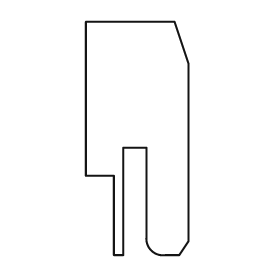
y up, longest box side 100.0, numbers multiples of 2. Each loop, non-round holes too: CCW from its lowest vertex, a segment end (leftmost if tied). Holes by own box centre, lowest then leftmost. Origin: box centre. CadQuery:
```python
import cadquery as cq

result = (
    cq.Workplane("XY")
    .moveTo(-10.0, -50.0)
    .lineTo(-6.0, -50.0)
    .lineTo(-6.0, -4.0)
    .lineTo(4.0, -4.0)
    .lineTo(4.0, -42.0)
    .threePointArc((6.0, -48.0), (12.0, -50.0))
    .lineTo(18.0, -50.0)
    .lineTo(22.0, -44.0)
    .lineTo(22.0, 32.0)
    .lineTo(16.0, 50.0)
    .lineTo(-22.0, 50.0)
    .lineTo(-22.0, -16.0)
    .lineTo(-10.0, -16.0)
    .close()
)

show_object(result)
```